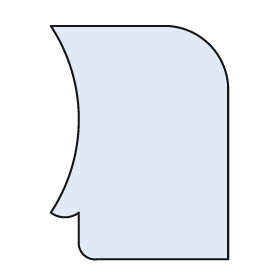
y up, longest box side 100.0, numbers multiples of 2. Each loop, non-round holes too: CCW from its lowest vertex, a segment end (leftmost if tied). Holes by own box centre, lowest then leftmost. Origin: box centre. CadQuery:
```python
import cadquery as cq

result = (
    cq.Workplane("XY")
    .moveTo(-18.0, -50.0)
    .lineTo(38.0, -50.0)
    .lineTo(38.0, 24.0)
    .threePointArc((30.0, 42.0), (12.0, 50.0))
    .lineTo(-38.0, 50.0)
    .threePointArc((-26.0, 10.0), (-38.0, -30.0))
    .threePointArc((-32.0, -32.0), (-26.0, -30.0))
    .lineTo(-26.0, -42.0)
    .threePointArc((-24.0, -48.0), (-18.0, -50.0))
    .close()
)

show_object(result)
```